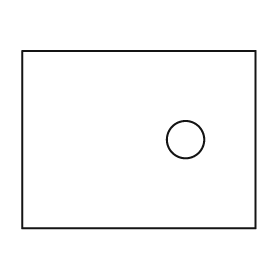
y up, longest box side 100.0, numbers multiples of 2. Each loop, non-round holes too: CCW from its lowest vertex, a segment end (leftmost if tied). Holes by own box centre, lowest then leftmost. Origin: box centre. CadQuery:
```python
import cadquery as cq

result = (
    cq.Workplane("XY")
    .moveTo(-50.0, -38.0)
    .lineTo(50.0, -38.0)
    .lineTo(50.0, 38.0)
    .lineTo(-50.0, 38.0)
    .close()
    .moveTo(20.0, 0.0)
    .circle(8.0)
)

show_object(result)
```